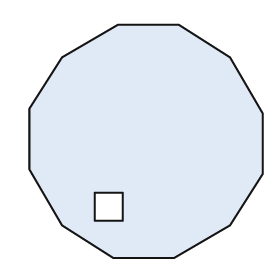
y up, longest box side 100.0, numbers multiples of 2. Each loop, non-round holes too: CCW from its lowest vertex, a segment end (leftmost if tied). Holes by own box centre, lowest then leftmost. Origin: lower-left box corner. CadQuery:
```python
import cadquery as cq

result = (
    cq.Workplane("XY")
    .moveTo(36.0, 0.0)
    .lineTo(62.0, 0.0)
    .lineTo(86.0, 14.0)
    .lineTo(100.0, 36.0)
    .lineTo(100.0, 62.0)
    .lineTo(86.0, 86.0)
    .lineTo(64.0, 100.0)
    .lineTo(38.0, 100.0)
    .lineTo(14.0, 86.0)
    .lineTo(0.0, 64.0)
    .lineTo(0.0, 38.0)
    .lineTo(14.0, 14.0)
    .close()
    .moveTo(28.0, 16.0)
    .lineTo(40.0, 16.0)
    .lineTo(40.0, 28.0)
    .lineTo(28.0, 28.0)
    .close()
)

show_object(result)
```